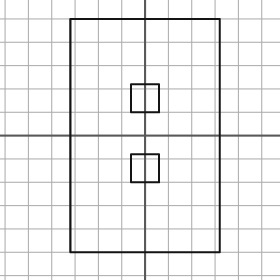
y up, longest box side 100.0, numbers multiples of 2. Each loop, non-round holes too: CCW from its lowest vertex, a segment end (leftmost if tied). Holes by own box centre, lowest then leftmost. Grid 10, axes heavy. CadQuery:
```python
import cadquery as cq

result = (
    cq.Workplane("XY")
    .moveTo(-32.0, -50.0)
    .lineTo(32.0, -50.0)
    .lineTo(32.0, 50.0)
    .lineTo(-32.0, 50.0)
    .close()
    .moveTo(-6.0, -20.0)
    .lineTo(6.0, -20.0)
    .lineTo(6.0, -8.0)
    .lineTo(-6.0, -8.0)
    .close()
    .moveTo(-6.0, 10.0)
    .lineTo(6.0, 10.0)
    .lineTo(6.0, 22.0)
    .lineTo(-6.0, 22.0)
    .close()
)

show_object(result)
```